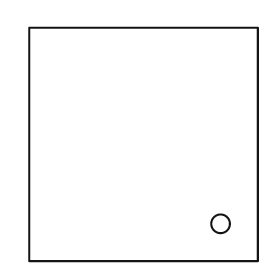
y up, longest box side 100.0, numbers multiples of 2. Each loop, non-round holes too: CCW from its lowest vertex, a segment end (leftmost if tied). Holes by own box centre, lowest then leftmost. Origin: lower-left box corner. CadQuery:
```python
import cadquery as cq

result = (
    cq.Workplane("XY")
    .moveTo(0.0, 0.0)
    .lineTo(98.0, 0.0)
    .lineTo(98.0, 100.0)
    .lineTo(0.0, 100.0)
    .close()
    .moveTo(82.0, 16.0)
    .circle(4.0)
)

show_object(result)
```